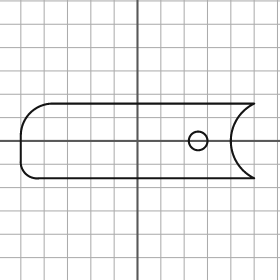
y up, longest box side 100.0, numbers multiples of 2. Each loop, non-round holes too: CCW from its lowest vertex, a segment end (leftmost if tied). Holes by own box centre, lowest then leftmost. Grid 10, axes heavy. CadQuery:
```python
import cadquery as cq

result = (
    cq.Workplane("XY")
    .moveTo(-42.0, -16.0)
    .lineTo(50.0, -16.0)
    .threePointArc((40.0, 0.0), (50.0, 16.0))
    .lineTo(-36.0, 16.0)
    .threePointArc((-46.0, 12.0), (-50.0, 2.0))
    .lineTo(-50.0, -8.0)
    .threePointArc((-48.0, -14.0), (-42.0, -16.0))
    .close()
    .moveTo(26.0, 0.0)
    .circle(4.0)
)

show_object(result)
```